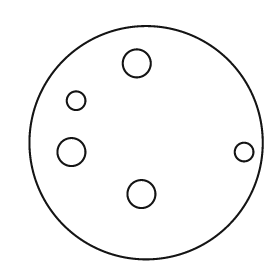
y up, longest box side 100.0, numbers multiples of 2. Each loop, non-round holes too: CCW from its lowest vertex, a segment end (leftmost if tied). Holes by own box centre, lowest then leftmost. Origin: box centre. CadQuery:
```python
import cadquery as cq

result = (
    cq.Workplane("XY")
    .moveTo(0.0, 0.0)
    .circle(50.0)
    .moveTo(-2.0, -22.0)
    .circle(6.0)
    .moveTo(-32.0, -4.0)
    .circle(6.0)
    .moveTo(42.0, -4.0)
    .circle(4.0)
    .moveTo(-30.0, 18.0)
    .circle(4.0)
    .moveTo(-4.0, 34.0)
    .circle(6.0)
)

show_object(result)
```